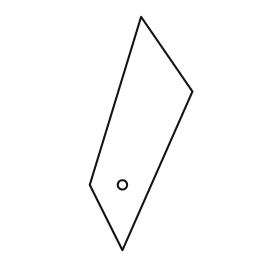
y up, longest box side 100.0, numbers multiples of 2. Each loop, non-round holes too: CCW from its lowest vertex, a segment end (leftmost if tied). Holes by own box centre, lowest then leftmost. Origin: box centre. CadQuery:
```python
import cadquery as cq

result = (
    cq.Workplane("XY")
    .moveTo(-8.0, -50.0)
    .lineTo(22.0, 18.0)
    .lineTo(0.0, 50.0)
    .lineTo(-22.0, -22.0)
    .close()
    .moveTo(-8.0, -22.0)
    .circle(2.0)
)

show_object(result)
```